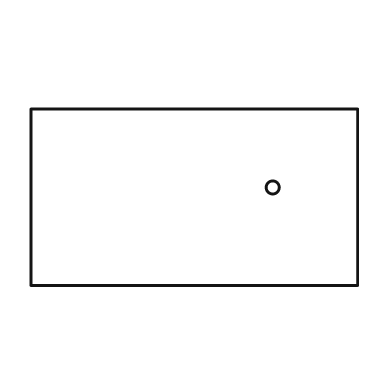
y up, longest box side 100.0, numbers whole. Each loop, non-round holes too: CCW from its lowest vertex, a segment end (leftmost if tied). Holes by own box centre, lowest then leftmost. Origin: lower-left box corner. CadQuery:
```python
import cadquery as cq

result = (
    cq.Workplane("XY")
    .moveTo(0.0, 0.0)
    .lineTo(100.0, 0.0)
    .lineTo(100.0, 54.0)
    .lineTo(0.0, 54.0)
    .close()
    .moveTo(74.0, 30.0)
    .circle(2.0)
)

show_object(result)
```